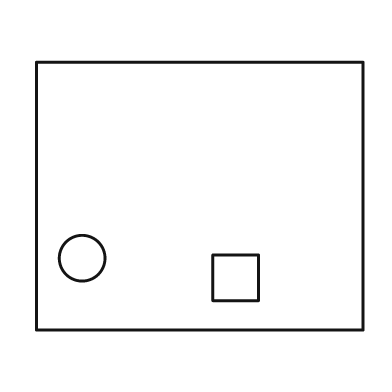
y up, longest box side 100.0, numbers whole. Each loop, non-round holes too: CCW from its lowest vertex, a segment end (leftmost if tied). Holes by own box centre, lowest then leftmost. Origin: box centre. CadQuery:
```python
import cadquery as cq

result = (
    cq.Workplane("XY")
    .moveTo(-50.0, -41.0)
    .lineTo(50.0, -41.0)
    .lineTo(50.0, 41.0)
    .lineTo(-50.0, 41.0)
    .close()
    .moveTo(4.0, -32.0)
    .lineTo(18.0, -32.0)
    .lineTo(18.0, -18.0)
    .lineTo(4.0, -18.0)
    .close()
    .moveTo(-36.0, -19.0)
    .circle(7.0)
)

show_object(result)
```